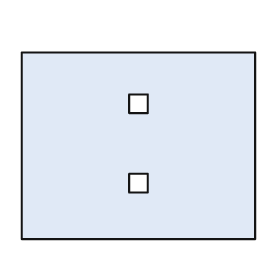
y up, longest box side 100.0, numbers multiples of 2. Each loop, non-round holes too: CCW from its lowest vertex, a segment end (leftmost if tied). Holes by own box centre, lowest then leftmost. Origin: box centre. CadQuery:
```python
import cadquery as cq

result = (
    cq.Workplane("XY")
    .moveTo(-50.0, -40.0)
    .lineTo(50.0, -40.0)
    .lineTo(50.0, 40.0)
    .lineTo(-50.0, 40.0)
    .close()
    .moveTo(-4.0, -20.0)
    .lineTo(4.0, -20.0)
    .lineTo(4.0, -12.0)
    .lineTo(-4.0, -12.0)
    .close()
    .moveTo(-4.0, 14.0)
    .lineTo(4.0, 14.0)
    .lineTo(4.0, 22.0)
    .lineTo(-4.0, 22.0)
    .close()
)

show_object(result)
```